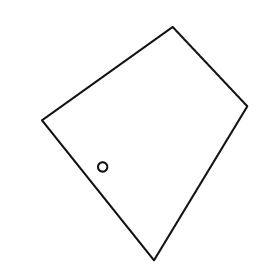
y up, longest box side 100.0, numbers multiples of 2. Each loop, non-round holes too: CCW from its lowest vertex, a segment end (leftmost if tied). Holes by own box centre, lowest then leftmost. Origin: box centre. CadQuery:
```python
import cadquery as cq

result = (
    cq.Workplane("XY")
    .moveTo(4.0, -50.0)
    .lineTo(44.0, 16.0)
    .lineTo(12.0, 50.0)
    .lineTo(-44.0, 10.0)
    .close()
    .moveTo(-18.0, -10.0)
    .circle(2.0)
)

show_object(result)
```